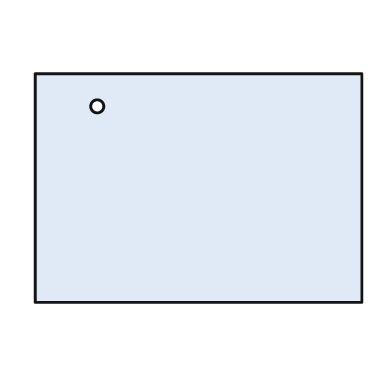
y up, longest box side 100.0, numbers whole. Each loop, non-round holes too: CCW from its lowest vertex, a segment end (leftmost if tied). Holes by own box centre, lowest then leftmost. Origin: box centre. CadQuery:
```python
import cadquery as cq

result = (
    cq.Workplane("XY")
    .moveTo(-50.0, -35.0)
    .lineTo(50.0, -35.0)
    .lineTo(50.0, 35.0)
    .lineTo(-50.0, 35.0)
    .close()
    .moveTo(-31.0, 25.0)
    .circle(2.0)
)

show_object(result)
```